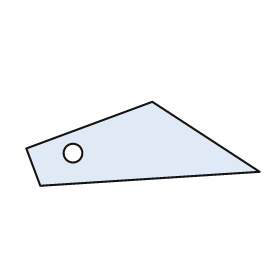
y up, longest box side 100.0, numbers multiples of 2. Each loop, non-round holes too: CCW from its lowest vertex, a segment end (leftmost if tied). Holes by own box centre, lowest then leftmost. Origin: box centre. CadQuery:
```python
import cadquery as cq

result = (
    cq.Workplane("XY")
    .moveTo(-44.0, -18.0)
    .lineTo(50.0, -12.0)
    .lineTo(4.0, 18.0)
    .lineTo(-50.0, -2.0)
    .close()
    .moveTo(-30.0, -4.0)
    .circle(4.0)
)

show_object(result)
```